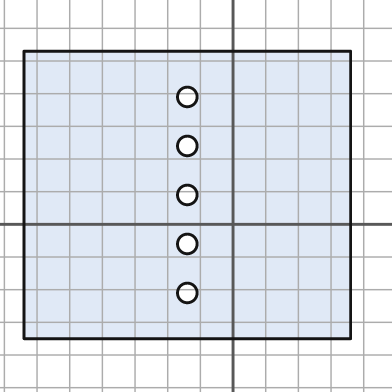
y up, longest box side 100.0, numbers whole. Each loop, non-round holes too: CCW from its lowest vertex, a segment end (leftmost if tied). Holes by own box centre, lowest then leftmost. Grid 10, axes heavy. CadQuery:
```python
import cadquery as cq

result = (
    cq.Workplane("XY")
    .moveTo(-64.0, -35.0)
    .lineTo(36.0, -35.0)
    .lineTo(36.0, 53.0)
    .lineTo(-64.0, 53.0)
    .close()
    .moveTo(-14.0, -21.0)
    .circle(3.0)
    .moveTo(-14.0, -6.0)
    .circle(3.0)
    .moveTo(-14.0, 9.0)
    .circle(3.0)
    .moveTo(-14.0, 24.0)
    .circle(3.0)
    .moveTo(-14.0, 39.0)
    .circle(3.0)
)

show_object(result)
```